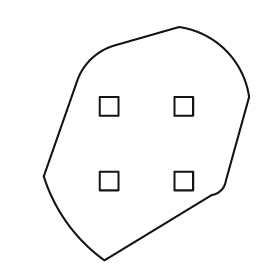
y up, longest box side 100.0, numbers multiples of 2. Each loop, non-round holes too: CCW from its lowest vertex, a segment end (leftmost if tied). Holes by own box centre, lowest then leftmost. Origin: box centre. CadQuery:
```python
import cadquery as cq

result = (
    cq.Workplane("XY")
    .moveTo(-18.0, -50.0)
    .lineTo(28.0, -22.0)
    .threePointArc((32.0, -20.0), (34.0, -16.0))
    .lineTo(44.0, 20.0)
    .threePointArc((34.0, 40.0), (14.0, 50.0))
    .lineTo(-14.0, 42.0)
    .threePointArc((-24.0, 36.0), (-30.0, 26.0))
    .lineTo(-44.0, -14.0)
    .threePointArc((-34.0, -34.0), (-18.0, -50.0))
    .close()
    .moveTo(-20.0, -20.0)
    .lineTo(-12.0, -20.0)
    .lineTo(-12.0, -12.0)
    .lineTo(-20.0, -12.0)
    .close()
    .moveTo(12.0, -20.0)
    .lineTo(20.0, -20.0)
    .lineTo(20.0, -12.0)
    .lineTo(12.0, -12.0)
    .close()
    .moveTo(-20.0, 12.0)
    .lineTo(-12.0, 12.0)
    .lineTo(-12.0, 20.0)
    .lineTo(-20.0, 20.0)
    .close()
    .moveTo(12.0, 12.0)
    .lineTo(20.0, 12.0)
    .lineTo(20.0, 20.0)
    .lineTo(12.0, 20.0)
    .close()
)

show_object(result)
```